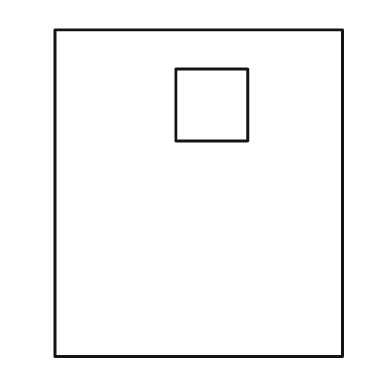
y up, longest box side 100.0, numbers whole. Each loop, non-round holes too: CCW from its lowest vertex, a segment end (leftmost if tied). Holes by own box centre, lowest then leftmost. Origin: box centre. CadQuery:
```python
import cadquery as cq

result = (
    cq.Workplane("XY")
    .moveTo(-44.0, -50.0)
    .lineTo(44.0, -50.0)
    .lineTo(44.0, 50.0)
    .lineTo(-44.0, 50.0)
    .close()
    .moveTo(-7.0, 16.0)
    .lineTo(15.0, 16.0)
    .lineTo(15.0, 38.0)
    .lineTo(-7.0, 38.0)
    .close()
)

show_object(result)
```